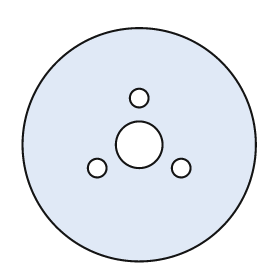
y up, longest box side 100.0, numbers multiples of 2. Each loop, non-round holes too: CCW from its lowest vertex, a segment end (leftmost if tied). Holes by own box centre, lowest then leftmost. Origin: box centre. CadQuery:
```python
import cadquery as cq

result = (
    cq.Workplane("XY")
    .moveTo(0.0, 0.0)
    .circle(50.0)
    .moveTo(-18.0, -10.0)
    .circle(4.0)
    .moveTo(18.0, -10.0)
    .circle(4.0)
    .moveTo(0.0, 0.0)
    .circle(10.0)
    .moveTo(0.0, 20.0)
    .circle(4.0)
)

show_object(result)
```